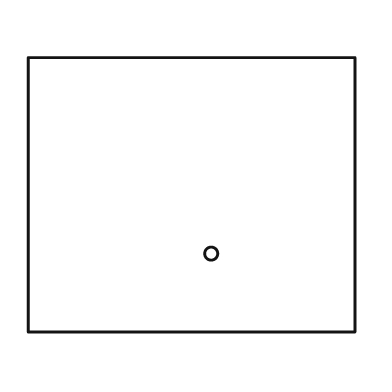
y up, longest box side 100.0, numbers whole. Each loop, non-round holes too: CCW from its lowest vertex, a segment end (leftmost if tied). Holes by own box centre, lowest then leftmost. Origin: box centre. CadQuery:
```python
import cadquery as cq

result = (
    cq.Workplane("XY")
    .moveTo(-50.0, -42.0)
    .lineTo(50.0, -42.0)
    .lineTo(50.0, 42.0)
    .lineTo(-50.0, 42.0)
    .close()
    .moveTo(6.0, -18.0)
    .circle(2.0)
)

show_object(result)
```